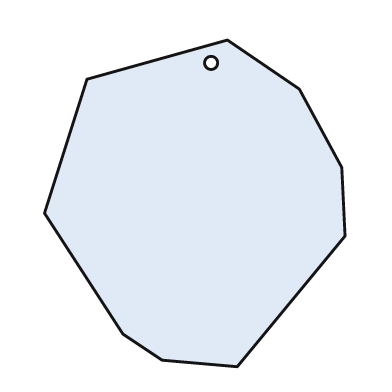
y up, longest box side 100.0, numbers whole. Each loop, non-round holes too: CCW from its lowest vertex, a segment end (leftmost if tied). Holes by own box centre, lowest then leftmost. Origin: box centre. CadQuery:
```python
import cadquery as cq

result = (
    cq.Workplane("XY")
    .moveTo(13.0, -50.0)
    .lineTo(46.0, -10.0)
    .lineTo(45.0, 11.0)
    .lineTo(32.0, 35.0)
    .lineTo(10.0, 50.0)
    .lineTo(-33.0, 38.0)
    .lineTo(-46.0, -3.0)
    .lineTo(-22.0, -40.0)
    .lineTo(-10.0, -48.0)
    .close()
    .moveTo(5.0, 43.0)
    .circle(2.0)
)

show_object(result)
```